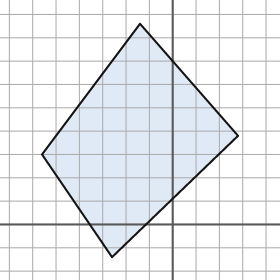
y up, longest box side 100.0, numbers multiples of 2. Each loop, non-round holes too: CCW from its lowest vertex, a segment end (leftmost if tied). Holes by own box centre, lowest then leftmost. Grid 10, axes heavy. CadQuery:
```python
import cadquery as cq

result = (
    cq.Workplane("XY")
    .moveTo(-26.0, -14.0)
    .lineTo(28.0, 38.0)
    .lineTo(-14.0, 86.0)
    .lineTo(-56.0, 30.0)
    .close()
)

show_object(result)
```